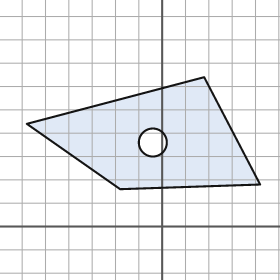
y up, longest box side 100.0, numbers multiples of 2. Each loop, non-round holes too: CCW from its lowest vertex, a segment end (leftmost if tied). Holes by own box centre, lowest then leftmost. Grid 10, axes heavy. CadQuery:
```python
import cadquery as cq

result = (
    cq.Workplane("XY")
    .moveTo(-18.0, 16.0)
    .lineTo(42.0, 18.0)
    .lineTo(18.0, 64.0)
    .lineTo(-58.0, 44.0)
    .close()
    .moveTo(-4.0, 36.0)
    .circle(6.0)
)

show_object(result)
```